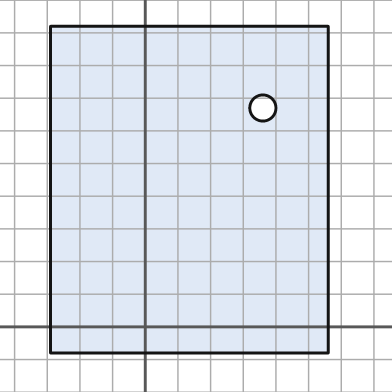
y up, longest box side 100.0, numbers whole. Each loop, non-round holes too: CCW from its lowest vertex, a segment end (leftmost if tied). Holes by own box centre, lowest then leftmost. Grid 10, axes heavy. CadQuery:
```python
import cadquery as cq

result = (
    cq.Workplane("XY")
    .moveTo(-29.0, -8.0)
    .lineTo(56.0, -8.0)
    .lineTo(56.0, 92.0)
    .lineTo(-29.0, 92.0)
    .close()
    .moveTo(36.0, 67.0)
    .circle(4.0)
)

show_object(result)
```